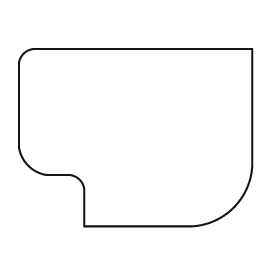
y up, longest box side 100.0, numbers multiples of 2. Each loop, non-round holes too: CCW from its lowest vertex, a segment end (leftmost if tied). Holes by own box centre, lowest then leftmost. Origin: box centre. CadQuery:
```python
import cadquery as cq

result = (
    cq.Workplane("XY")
    .moveTo(-22.0, -38.0)
    .lineTo(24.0, -38.0)
    .threePointArc((42.0, -30.0), (50.0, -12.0))
    .lineTo(50.0, 38.0)
    .lineTo(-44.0, 38.0)
    .threePointArc((-48.0, 36.0), (-50.0, 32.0))
    .lineTo(-50.0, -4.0)
    .threePointArc((-46.0, -12.0), (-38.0, -16.0))
    .lineTo(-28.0, -16.0)
    .threePointArc((-24.0, -18.0), (-22.0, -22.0))
    .close()
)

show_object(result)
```